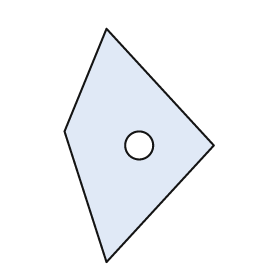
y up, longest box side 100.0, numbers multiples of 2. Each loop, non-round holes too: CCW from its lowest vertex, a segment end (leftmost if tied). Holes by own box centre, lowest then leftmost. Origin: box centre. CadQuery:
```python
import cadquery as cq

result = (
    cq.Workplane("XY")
    .moveTo(-14.0, -50.0)
    .lineTo(32.0, 0.0)
    .lineTo(-14.0, 50.0)
    .lineTo(-32.0, 6.0)
    .close()
    .moveTo(0.0, 0.0)
    .circle(6.0)
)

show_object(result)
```